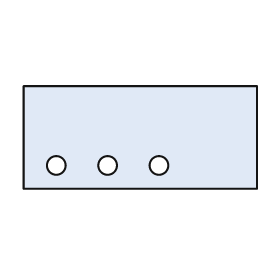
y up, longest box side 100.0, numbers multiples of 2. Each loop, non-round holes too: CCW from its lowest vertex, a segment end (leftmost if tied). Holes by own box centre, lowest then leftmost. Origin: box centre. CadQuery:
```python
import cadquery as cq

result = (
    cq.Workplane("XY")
    .moveTo(-50.0, -22.0)
    .lineTo(50.0, -22.0)
    .lineTo(50.0, 22.0)
    .lineTo(-50.0, 22.0)
    .close()
    .moveTo(-36.0, -12.0)
    .circle(4.0)
    .moveTo(-14.0, -12.0)
    .circle(4.0)
    .moveTo(8.0, -12.0)
    .circle(4.0)
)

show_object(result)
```